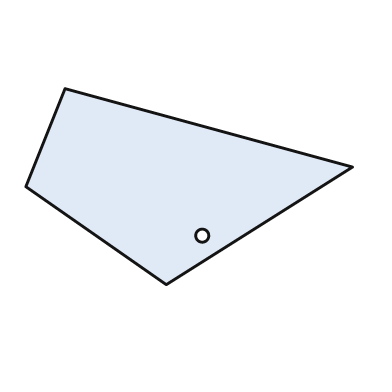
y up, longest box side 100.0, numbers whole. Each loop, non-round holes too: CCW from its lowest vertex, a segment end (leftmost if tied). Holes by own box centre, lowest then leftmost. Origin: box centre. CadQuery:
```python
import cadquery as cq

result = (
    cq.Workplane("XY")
    .moveTo(-7.0, -30.0)
    .lineTo(50.0, 6.0)
    .lineTo(-38.0, 30.0)
    .lineTo(-50.0, 0.0)
    .close()
    .moveTo(4.0, -15.0)
    .circle(2.0)
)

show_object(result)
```